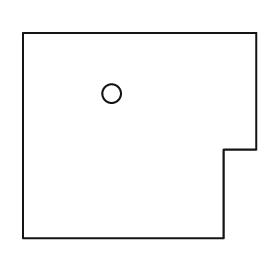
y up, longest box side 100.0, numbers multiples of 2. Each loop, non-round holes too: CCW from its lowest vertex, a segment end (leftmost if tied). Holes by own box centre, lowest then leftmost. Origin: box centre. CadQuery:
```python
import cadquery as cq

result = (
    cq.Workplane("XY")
    .moveTo(-50.0, -44.0)
    .lineTo(36.0, -44.0)
    .lineTo(36.0, -6.0)
    .lineTo(50.0, -6.0)
    .lineTo(50.0, 44.0)
    .lineTo(-50.0, 44.0)
    .close()
    .moveTo(-12.0, 18.0)
    .circle(4.0)
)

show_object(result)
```